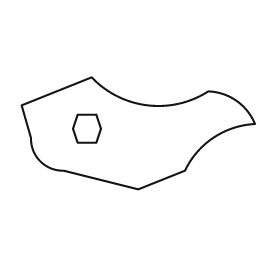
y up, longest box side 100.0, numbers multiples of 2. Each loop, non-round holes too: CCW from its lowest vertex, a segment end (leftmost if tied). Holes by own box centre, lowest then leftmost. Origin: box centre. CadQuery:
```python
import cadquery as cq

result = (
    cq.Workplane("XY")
    .moveTo(0.0, -24.0)
    .lineTo(20.0, -16.0)
    .threePointArc((32.0, -2.0), (50.0, 4.0))
    .threePointArc((42.0, 14.0), (30.0, 18.0))
    .threePointArc((4.0, 12.0), (-20.0, 24.0))
    .lineTo(-50.0, 12.0)
    .lineTo(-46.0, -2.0)
    .threePointArc((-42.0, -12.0), (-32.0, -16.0))
    .close()
    .moveTo(-26.0, -4.0)
    .lineTo(-18.0, -4.0)
    .lineTo(-16.0, 2.0)
    .lineTo(-18.0, 8.0)
    .lineTo(-26.0, 8.0)
    .lineTo(-28.0, 2.0)
    .close()
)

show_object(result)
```